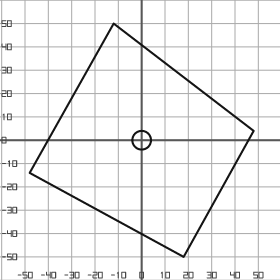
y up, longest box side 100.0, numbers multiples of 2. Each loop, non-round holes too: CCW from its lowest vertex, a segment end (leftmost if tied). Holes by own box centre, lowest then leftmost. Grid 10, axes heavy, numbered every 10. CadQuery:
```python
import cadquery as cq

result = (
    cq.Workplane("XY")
    .moveTo(18.0, -50.0)
    .lineTo(48.0, 4.0)
    .lineTo(-12.0, 50.0)
    .lineTo(-48.0, -14.0)
    .close()
    .moveTo(0.0, 0.0)
    .circle(4.0)
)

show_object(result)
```